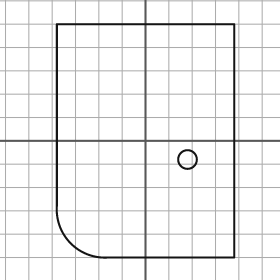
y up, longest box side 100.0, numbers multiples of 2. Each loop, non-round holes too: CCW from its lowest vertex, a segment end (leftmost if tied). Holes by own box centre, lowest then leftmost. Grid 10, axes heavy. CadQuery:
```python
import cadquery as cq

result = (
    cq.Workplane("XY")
    .moveTo(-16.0, -50.0)
    .lineTo(38.0, -50.0)
    .lineTo(38.0, 50.0)
    .lineTo(-38.0, 50.0)
    .lineTo(-38.0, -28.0)
    .threePointArc((-32.0, -44.0), (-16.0, -50.0))
    .close()
    .moveTo(18.0, -8.0)
    .circle(4.0)
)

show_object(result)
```